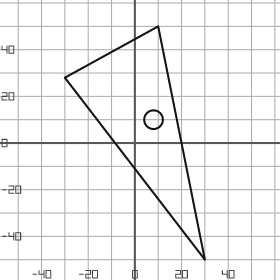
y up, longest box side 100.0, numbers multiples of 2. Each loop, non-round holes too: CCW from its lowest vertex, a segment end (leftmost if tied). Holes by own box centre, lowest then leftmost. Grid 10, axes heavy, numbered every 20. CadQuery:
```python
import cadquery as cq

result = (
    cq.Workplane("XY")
    .moveTo(30.0, -50.0)
    .lineTo(10.0, 50.0)
    .lineTo(-30.0, 28.0)
    .close()
    .moveTo(8.0, 10.0)
    .circle(4.0)
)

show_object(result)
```